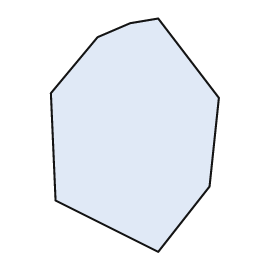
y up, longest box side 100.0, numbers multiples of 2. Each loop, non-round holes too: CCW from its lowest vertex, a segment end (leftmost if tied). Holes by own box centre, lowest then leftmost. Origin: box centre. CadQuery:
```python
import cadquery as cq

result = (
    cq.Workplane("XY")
    .moveTo(10.0, -50.0)
    .lineTo(32.0, -22.0)
    .lineTo(36.0, 16.0)
    .lineTo(10.0, 50.0)
    .lineTo(-2.0, 48.0)
    .lineTo(-16.0, 42.0)
    .lineTo(-36.0, 18.0)
    .lineTo(-34.0, -28.0)
    .close()
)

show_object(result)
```